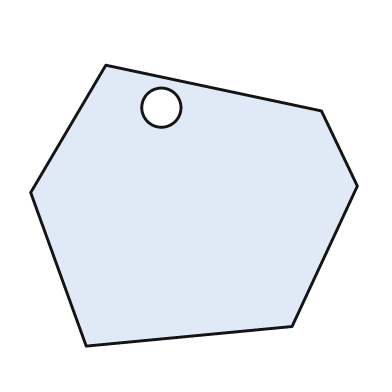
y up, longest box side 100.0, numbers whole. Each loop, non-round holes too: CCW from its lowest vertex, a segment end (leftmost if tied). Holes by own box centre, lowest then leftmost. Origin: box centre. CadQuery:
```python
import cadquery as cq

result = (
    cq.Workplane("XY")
    .moveTo(-33.0, -43.0)
    .lineTo(30.0, -37.0)
    .lineTo(50.0, 6.0)
    .lineTo(39.0, 29.0)
    .lineTo(-27.0, 43.0)
    .lineTo(-50.0, 4.0)
    .close()
    .moveTo(-10.0, 30.0)
    .circle(6.0)
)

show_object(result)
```